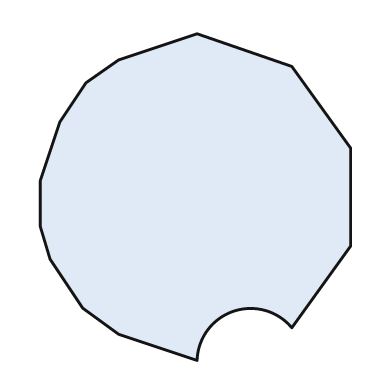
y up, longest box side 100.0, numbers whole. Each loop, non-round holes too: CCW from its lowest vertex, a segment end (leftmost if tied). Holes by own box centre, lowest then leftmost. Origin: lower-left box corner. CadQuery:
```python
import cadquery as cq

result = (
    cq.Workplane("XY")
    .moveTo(48.0, 0.0)
    .threePointArc((59.0, 15.0), (77.0, 10.0))
    .lineTo(95.0, 35.0)
    .lineTo(95.0, 65.0)
    .lineTo(77.0, 90.0)
    .lineTo(48.0, 100.0)
    .lineTo(24.0, 92.0)
    .lineTo(14.0, 85.0)
    .lineTo(6.0, 73.0)
    .lineTo(0.0, 55.0)
    .lineTo(0.0, 41.0)
    .lineTo(3.0, 31.0)
    .lineTo(13.0, 16.0)
    .lineTo(24.0, 8.0)
    .close()
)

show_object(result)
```